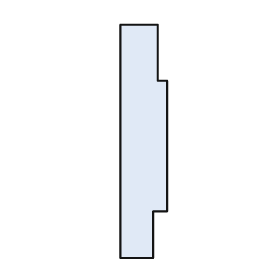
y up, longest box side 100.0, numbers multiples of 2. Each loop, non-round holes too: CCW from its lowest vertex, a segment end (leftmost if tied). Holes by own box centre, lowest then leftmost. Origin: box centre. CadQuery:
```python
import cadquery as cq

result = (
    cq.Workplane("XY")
    .moveTo(-10.0, -50.0)
    .lineTo(4.0, -50.0)
    .lineTo(4.0, -30.0)
    .lineTo(10.0, -30.0)
    .lineTo(10.0, 26.0)
    .lineTo(6.0, 26.0)
    .lineTo(6.0, 50.0)
    .lineTo(-10.0, 50.0)
    .close()
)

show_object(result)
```